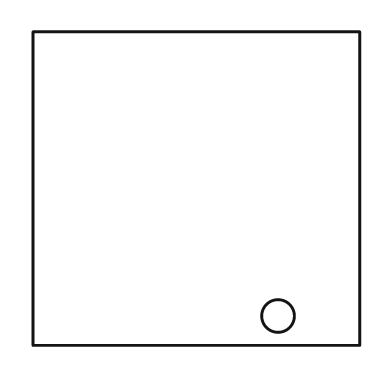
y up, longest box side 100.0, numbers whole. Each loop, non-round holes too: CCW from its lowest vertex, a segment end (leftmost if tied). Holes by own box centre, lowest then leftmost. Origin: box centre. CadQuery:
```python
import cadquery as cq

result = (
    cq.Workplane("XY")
    .moveTo(-50.0, -48.0)
    .lineTo(50.0, -48.0)
    .lineTo(50.0, 48.0)
    .lineTo(-50.0, 48.0)
    .close()
    .moveTo(25.0, -39.0)
    .circle(5.0)
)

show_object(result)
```